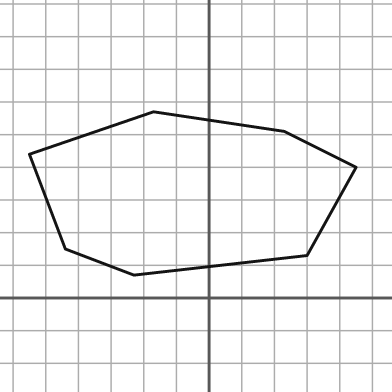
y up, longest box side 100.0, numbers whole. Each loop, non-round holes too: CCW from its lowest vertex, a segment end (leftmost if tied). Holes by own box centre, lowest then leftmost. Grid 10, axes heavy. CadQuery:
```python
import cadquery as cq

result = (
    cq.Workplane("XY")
    .moveTo(-23.0, 7.0)
    .lineTo(30.0, 13.0)
    .lineTo(45.0, 40.0)
    .lineTo(23.0, 51.0)
    .lineTo(-17.0, 57.0)
    .lineTo(-55.0, 44.0)
    .lineTo(-44.0, 15.0)
    .close()
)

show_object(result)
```